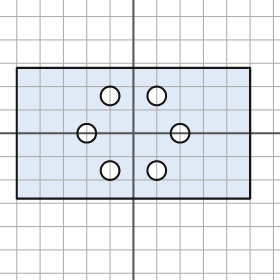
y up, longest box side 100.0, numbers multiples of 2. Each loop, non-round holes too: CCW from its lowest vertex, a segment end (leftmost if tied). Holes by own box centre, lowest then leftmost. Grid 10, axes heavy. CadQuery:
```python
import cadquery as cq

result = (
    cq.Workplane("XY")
    .moveTo(-50.0, -28.0)
    .lineTo(50.0, -28.0)
    .lineTo(50.0, 28.0)
    .lineTo(-50.0, 28.0)
    .close()
    .moveTo(-10.0, -16.0)
    .circle(4.0)
    .moveTo(10.0, -16.0)
    .circle(4.0)
    .moveTo(-20.0, 0.0)
    .circle(4.0)
    .moveTo(20.0, 0.0)
    .circle(4.0)
    .moveTo(-10.0, 16.0)
    .circle(4.0)
    .moveTo(10.0, 16.0)
    .circle(4.0)
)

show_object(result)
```